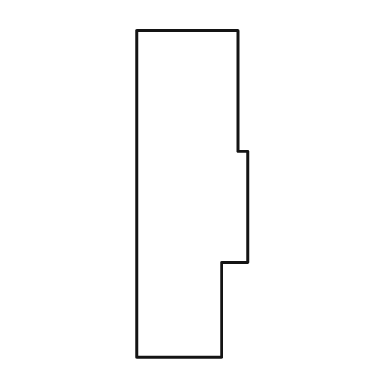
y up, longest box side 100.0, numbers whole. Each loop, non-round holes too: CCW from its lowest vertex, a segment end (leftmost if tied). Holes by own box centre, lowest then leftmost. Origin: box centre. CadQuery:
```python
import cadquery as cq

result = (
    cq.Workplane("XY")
    .moveTo(-17.0, -50.0)
    .lineTo(9.0, -50.0)
    .lineTo(9.0, -21.0)
    .lineTo(17.0, -21.0)
    .lineTo(17.0, 13.0)
    .lineTo(14.0, 13.0)
    .lineTo(14.0, 50.0)
    .lineTo(-17.0, 50.0)
    .close()
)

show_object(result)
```